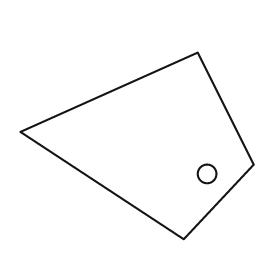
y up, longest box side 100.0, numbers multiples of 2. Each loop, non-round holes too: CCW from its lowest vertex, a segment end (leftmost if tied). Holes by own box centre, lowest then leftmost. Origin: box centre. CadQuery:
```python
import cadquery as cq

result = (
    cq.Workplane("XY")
    .moveTo(20.0, -40.0)
    .lineTo(50.0, -8.0)
    .lineTo(26.0, 40.0)
    .lineTo(-50.0, 6.0)
    .close()
    .moveTo(30.0, -12.0)
    .circle(4.0)
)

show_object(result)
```